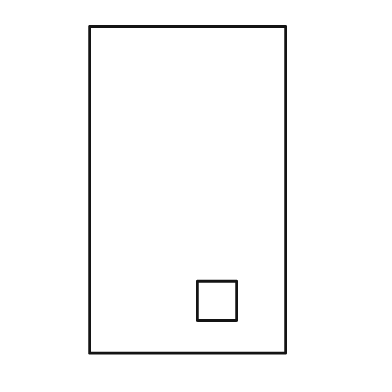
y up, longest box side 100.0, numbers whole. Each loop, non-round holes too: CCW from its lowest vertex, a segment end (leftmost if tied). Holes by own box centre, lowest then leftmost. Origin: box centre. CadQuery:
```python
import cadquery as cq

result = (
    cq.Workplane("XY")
    .moveTo(-30.0, -50.0)
    .lineTo(30.0, -50.0)
    .lineTo(30.0, 50.0)
    .lineTo(-30.0, 50.0)
    .close()
    .moveTo(3.0, -40.0)
    .lineTo(15.0, -40.0)
    .lineTo(15.0, -28.0)
    .lineTo(3.0, -28.0)
    .close()
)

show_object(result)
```